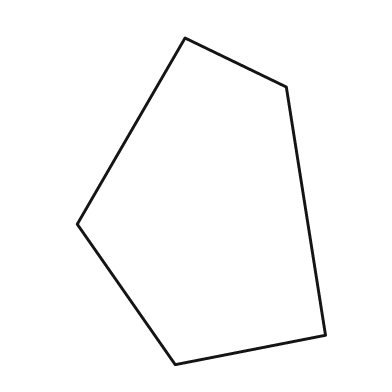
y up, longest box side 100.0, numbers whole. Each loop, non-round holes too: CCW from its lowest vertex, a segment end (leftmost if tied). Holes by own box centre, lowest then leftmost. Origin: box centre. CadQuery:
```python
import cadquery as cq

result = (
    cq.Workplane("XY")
    .moveTo(-8.0, -50.0)
    .lineTo(38.0, -41.0)
    .lineTo(26.0, 35.0)
    .lineTo(-5.0, 50.0)
    .lineTo(-38.0, -7.0)
    .close()
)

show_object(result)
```